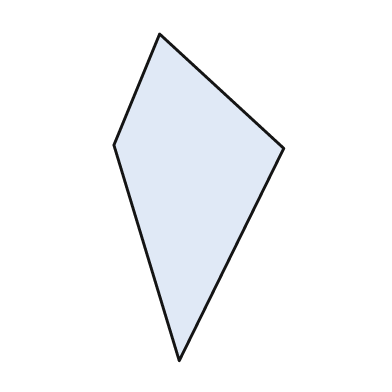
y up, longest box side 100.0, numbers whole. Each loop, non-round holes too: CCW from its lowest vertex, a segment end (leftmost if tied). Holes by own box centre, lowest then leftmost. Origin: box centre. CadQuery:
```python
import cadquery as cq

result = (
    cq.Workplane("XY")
    .moveTo(-6.0, -50.0)
    .lineTo(26.0, 15.0)
    .lineTo(-12.0, 50.0)
    .lineTo(-26.0, 16.0)
    .close()
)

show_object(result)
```